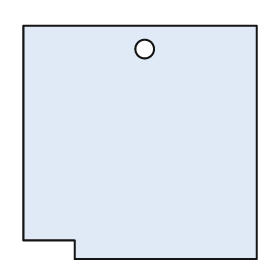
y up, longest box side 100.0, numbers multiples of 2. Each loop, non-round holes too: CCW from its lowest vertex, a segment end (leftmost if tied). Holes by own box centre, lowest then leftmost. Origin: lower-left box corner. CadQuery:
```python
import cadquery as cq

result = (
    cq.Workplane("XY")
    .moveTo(22.0, 0.0)
    .lineTo(100.0, 0.0)
    .lineTo(100.0, 100.0)
    .lineTo(0.0, 100.0)
    .lineTo(0.0, 8.0)
    .lineTo(22.0, 8.0)
    .close()
    .moveTo(52.0, 90.0)
    .circle(4.0)
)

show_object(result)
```